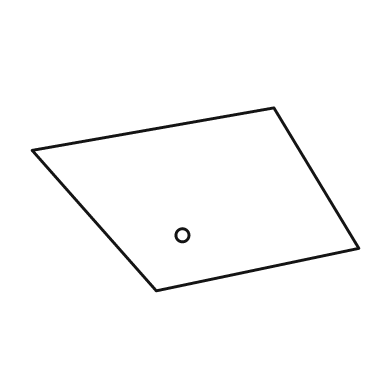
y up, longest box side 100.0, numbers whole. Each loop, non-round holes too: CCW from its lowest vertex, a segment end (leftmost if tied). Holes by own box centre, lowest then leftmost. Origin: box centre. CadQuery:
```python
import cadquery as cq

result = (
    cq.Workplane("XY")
    .moveTo(-12.0, -28.0)
    .lineTo(50.0, -15.0)
    .lineTo(24.0, 28.0)
    .lineTo(-50.0, 15.0)
    .close()
    .moveTo(-4.0, -11.0)
    .circle(2.0)
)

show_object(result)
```